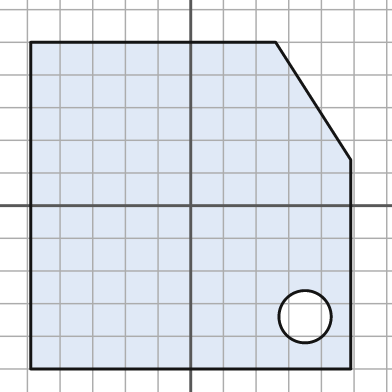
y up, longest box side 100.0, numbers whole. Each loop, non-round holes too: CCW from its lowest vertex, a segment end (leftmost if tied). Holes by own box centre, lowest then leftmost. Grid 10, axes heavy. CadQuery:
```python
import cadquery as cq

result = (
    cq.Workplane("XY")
    .moveTo(-49.0, -50.0)
    .lineTo(49.0, -50.0)
    .lineTo(49.0, 14.0)
    .lineTo(26.0, 50.0)
    .lineTo(-49.0, 50.0)
    .close()
    .moveTo(35.0, -34.0)
    .circle(8.0)
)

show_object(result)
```